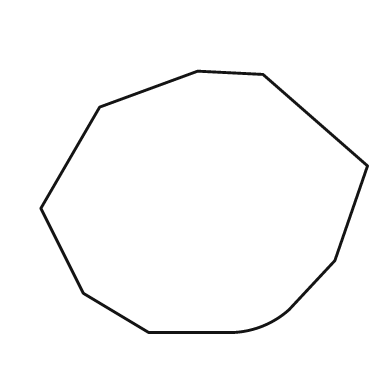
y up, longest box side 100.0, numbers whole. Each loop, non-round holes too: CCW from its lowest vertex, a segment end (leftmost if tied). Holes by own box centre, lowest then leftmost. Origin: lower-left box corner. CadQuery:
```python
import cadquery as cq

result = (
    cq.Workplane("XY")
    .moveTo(33.0, 0.0)
    .lineTo(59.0, 0.0)
    .threePointArc((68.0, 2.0), (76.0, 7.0))
    .lineTo(90.0, 22.0)
    .lineTo(100.0, 51.0)
    .lineTo(68.0, 79.0)
    .lineTo(48.0, 80.0)
    .lineTo(18.0, 69.0)
    .lineTo(0.0, 38.0)
    .lineTo(13.0, 12.0)
    .close()
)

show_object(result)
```